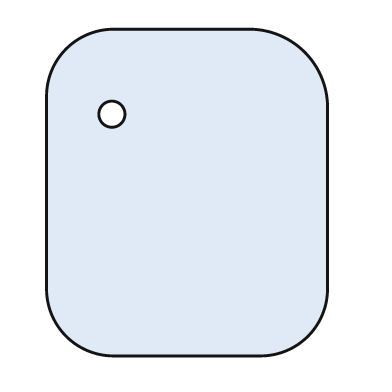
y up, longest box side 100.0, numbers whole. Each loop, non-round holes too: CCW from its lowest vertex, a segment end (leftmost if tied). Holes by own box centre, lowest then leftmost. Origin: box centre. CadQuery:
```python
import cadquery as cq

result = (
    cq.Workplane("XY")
    .moveTo(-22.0, -50.0)
    .lineTo(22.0, -50.0)
    .threePointArc((37.0, -44.0), (43.0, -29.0))
    .lineTo(43.0, 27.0)
    .threePointArc((36.0, 43.0), (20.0, 50.0))
    .lineTo(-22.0, 50.0)
    .threePointArc((-37.0, 44.0), (-43.0, 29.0))
    .lineTo(-43.0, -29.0)
    .threePointArc((-37.0, -44.0), (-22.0, -50.0))
    .close()
    .moveTo(-23.0, 24.0)
    .circle(4.0)
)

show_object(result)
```